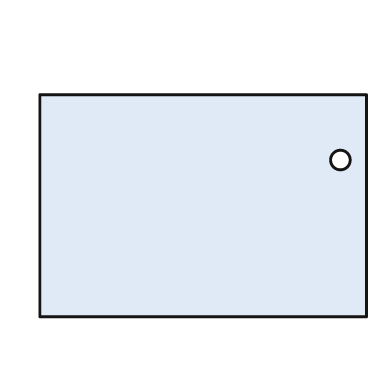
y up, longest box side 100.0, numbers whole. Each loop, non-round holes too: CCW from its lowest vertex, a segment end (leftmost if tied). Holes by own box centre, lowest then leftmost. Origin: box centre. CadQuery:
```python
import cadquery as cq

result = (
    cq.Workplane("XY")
    .moveTo(-50.0, -34.0)
    .lineTo(50.0, -34.0)
    .lineTo(50.0, 34.0)
    .lineTo(-50.0, 34.0)
    .close()
    .moveTo(42.0, 14.0)
    .circle(3.0)
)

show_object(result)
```